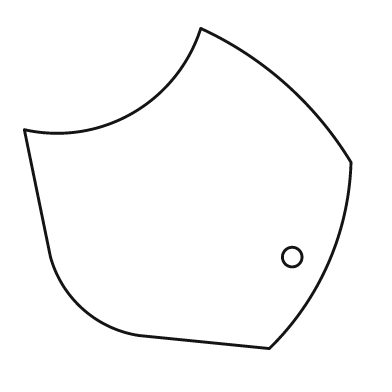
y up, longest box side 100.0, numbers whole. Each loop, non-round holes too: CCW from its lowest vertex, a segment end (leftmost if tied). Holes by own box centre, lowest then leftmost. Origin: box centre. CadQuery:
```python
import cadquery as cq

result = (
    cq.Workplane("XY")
    .moveTo(25.0, -49.0)
    .threePointArc((43.0, -23.0), (50.0, 8.0))
    .threePointArc((30.0, 32.0), (4.0, 49.0))
    .threePointArc((-17.0, 23.0), (-50.0, 18.0))
    .lineTo(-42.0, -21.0)
    .threePointArc((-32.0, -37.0), (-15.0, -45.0))
    .close()
    .moveTo(32.0, -21.0)
    .circle(3.0)
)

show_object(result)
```